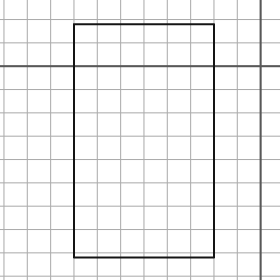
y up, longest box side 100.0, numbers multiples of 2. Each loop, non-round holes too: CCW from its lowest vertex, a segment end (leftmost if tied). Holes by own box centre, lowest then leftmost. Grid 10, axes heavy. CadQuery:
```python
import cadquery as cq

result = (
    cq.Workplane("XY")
    .moveTo(-80.0, -82.0)
    .lineTo(-20.0, -82.0)
    .lineTo(-20.0, 18.0)
    .lineTo(-80.0, 18.0)
    .close()
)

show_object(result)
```